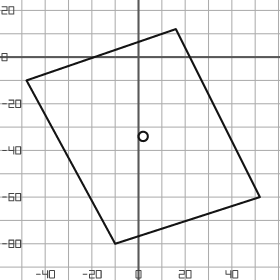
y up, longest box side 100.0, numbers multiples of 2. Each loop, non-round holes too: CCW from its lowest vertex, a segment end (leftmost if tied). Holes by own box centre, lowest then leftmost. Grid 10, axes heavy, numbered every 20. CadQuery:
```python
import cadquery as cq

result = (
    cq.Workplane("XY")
    .moveTo(-10.0, -80.0)
    .lineTo(52.0, -60.0)
    .lineTo(16.0, 12.0)
    .lineTo(-48.0, -10.0)
    .close()
    .moveTo(2.0, -34.0)
    .circle(2.0)
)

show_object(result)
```